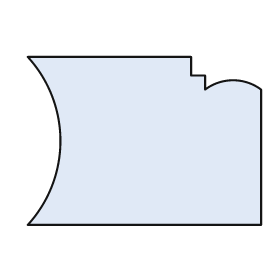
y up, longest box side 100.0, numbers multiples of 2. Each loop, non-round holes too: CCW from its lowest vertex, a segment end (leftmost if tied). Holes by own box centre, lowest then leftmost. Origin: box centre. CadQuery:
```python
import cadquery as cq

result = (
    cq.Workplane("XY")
    .moveTo(-50.0, -36.0)
    .lineTo(50.0, -36.0)
    .lineTo(50.0, 22.0)
    .threePointArc((38.0, 26.0), (26.0, 22.0))
    .lineTo(26.0, 28.0)
    .lineTo(20.0, 28.0)
    .lineTo(20.0, 36.0)
    .lineTo(-50.0, 36.0)
    .threePointArc((-36.0, 0.0), (-50.0, -36.0))
    .close()
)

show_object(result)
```